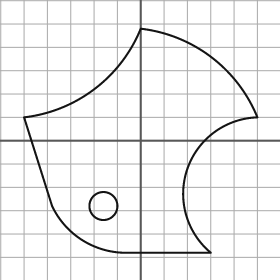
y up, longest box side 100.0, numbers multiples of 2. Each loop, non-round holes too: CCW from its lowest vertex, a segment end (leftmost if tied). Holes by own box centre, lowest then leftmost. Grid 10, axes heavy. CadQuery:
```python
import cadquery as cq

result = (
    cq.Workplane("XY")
    .moveTo(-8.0, -48.0)
    .lineTo(30.0, -48.0)
    .threePointArc((20.0, -12.0), (50.0, 10.0))
    .threePointArc((30.0, 36.0), (0.0, 48.0))
    .threePointArc((-20.0, 22.0), (-50.0, 10.0))
    .lineTo(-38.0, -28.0)
    .threePointArc((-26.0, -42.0), (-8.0, -48.0))
    .close()
    .moveTo(-16.0, -28.0)
    .circle(6.0)
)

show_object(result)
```